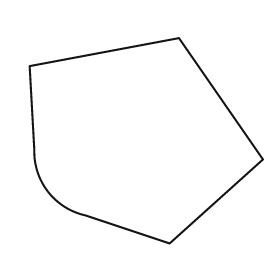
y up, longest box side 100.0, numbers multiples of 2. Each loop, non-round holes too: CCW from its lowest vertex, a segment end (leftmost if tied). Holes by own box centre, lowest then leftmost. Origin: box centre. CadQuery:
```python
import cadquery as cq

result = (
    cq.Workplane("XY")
    .moveTo(10.0, -44.0)
    .lineTo(50.0, -8.0)
    .lineTo(14.0, 44.0)
    .lineTo(-50.0, 32.0)
    .lineTo(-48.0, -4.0)
    .threePointArc((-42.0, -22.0), (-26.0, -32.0))
    .close()
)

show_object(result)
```